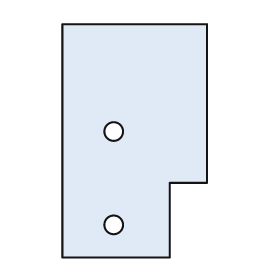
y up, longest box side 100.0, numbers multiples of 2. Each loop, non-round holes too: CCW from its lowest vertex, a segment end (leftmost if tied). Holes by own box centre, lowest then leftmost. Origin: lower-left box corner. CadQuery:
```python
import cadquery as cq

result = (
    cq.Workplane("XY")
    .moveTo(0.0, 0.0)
    .lineTo(46.0, 0.0)
    .lineTo(46.0, 32.0)
    .lineTo(62.0, 32.0)
    .lineTo(62.0, 100.0)
    .lineTo(0.0, 100.0)
    .close()
    .moveTo(22.0, 14.0)
    .circle(4.0)
    .moveTo(22.0, 54.0)
    .circle(4.0)
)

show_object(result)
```